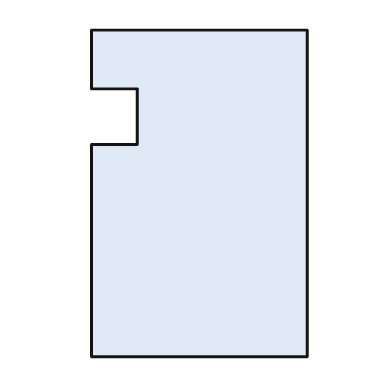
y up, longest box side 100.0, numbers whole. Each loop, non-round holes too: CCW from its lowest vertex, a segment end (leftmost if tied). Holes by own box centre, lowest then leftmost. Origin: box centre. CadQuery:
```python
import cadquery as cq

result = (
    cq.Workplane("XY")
    .moveTo(-33.0, -50.0)
    .lineTo(33.0, -50.0)
    .lineTo(33.0, 50.0)
    .lineTo(-33.0, 50.0)
    .lineTo(-33.0, 32.0)
    .lineTo(-19.0, 32.0)
    .lineTo(-19.0, 15.0)
    .lineTo(-33.0, 15.0)
    .close()
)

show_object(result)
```